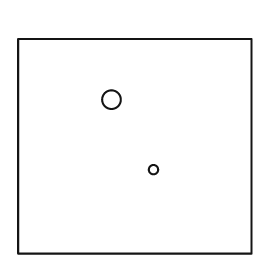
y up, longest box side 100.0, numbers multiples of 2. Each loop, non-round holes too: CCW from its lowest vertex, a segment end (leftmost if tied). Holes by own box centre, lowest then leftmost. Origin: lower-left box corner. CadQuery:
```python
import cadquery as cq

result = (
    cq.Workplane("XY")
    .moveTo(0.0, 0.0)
    .lineTo(100.0, 0.0)
    .lineTo(100.0, 92.0)
    .lineTo(0.0, 92.0)
    .close()
    .moveTo(58.0, 36.0)
    .circle(2.0)
    .moveTo(40.0, 66.0)
    .circle(4.0)
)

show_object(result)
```